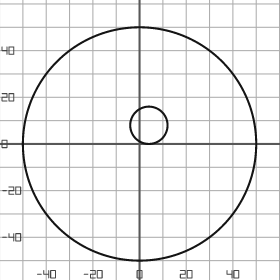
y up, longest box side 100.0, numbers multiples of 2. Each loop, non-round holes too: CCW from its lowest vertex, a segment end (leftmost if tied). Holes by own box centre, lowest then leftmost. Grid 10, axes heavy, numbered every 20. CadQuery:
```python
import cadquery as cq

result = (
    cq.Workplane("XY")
    .moveTo(0.0, 0.0)
    .circle(50.0)
    .moveTo(4.0, 8.0)
    .circle(8.0)
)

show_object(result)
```